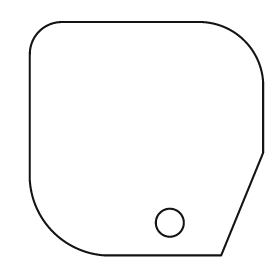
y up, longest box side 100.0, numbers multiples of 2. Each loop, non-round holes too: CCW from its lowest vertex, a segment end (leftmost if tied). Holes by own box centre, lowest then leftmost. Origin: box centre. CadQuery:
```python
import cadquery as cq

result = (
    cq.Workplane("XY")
    .moveTo(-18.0, -50.0)
    .lineTo(32.0, -50.0)
    .lineTo(50.0, -6.0)
    .lineTo(50.0, 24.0)
    .threePointArc((42.0, 42.0), (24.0, 50.0))
    .lineTo(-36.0, 50.0)
    .threePointArc((-46.0, 46.0), (-50.0, 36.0))
    .lineTo(-50.0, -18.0)
    .threePointArc((-40.0, -40.0), (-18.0, -50.0))
    .close()
    .moveTo(10.0, -36.0)
    .circle(6.0)
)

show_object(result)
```